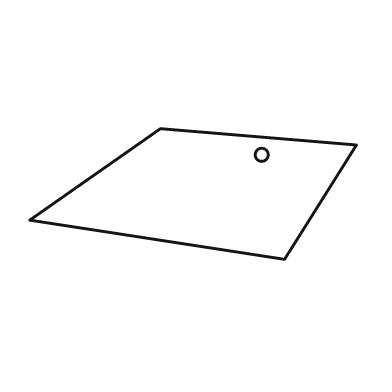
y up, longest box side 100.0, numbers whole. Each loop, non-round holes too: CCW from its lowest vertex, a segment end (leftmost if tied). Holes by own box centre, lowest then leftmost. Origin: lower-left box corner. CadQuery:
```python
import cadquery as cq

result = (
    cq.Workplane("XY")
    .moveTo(78.0, 0.0)
    .lineTo(100.0, 35.0)
    .lineTo(40.0, 40.0)
    .lineTo(0.0, 12.0)
    .close()
    .moveTo(71.0, 32.0)
    .circle(2.0)
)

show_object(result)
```